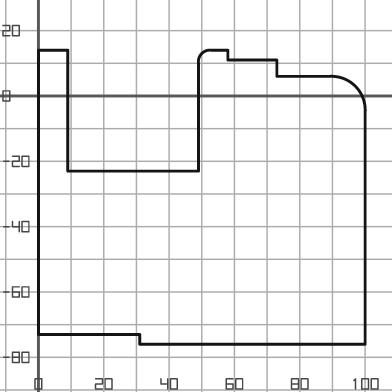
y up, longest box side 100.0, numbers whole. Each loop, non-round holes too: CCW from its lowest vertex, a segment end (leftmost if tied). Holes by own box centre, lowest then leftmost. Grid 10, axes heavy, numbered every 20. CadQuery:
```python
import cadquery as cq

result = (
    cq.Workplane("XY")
    .moveTo(31.0, -76.0)
    .lineTo(100.0, -76.0)
    .lineTo(100.0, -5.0)
    .threePointArc((97.0, 3.0), (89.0, 6.0))
    .lineTo(73.0, 6.0)
    .lineTo(73.0, 11.0)
    .lineTo(58.0, 11.0)
    .lineTo(58.0, 14.0)
    .lineTo(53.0, 14.0)
    .threePointArc((50.0, 13.0), (49.0, 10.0))
    .lineTo(49.0, -23.0)
    .lineTo(9.0, -23.0)
    .lineTo(9.0, 14.0)
    .lineTo(0.0, 14.0)
    .lineTo(0.0, -73.0)
    .lineTo(31.0, -73.0)
    .close()
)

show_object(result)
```